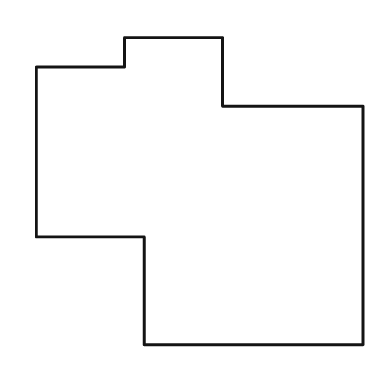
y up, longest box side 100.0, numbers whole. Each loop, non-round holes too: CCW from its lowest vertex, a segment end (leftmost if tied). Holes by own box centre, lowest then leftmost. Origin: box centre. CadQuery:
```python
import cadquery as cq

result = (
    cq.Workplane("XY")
    .moveTo(-17.0, -47.0)
    .lineTo(50.0, -47.0)
    .lineTo(50.0, 26.0)
    .lineTo(7.0, 26.0)
    .lineTo(7.0, 47.0)
    .lineTo(-23.0, 47.0)
    .lineTo(-23.0, 38.0)
    .lineTo(-50.0, 38.0)
    .lineTo(-50.0, -14.0)
    .lineTo(-17.0, -14.0)
    .close()
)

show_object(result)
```